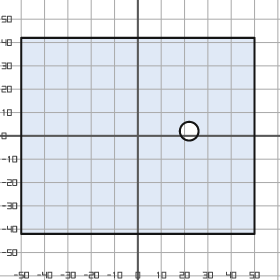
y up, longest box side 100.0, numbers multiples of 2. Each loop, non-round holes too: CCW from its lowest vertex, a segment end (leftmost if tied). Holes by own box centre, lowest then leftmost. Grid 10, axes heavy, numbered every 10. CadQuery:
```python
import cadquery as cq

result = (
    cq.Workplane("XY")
    .moveTo(-50.0, -42.0)
    .lineTo(50.0, -42.0)
    .lineTo(50.0, 42.0)
    .lineTo(-50.0, 42.0)
    .close()
    .moveTo(22.0, 2.0)
    .circle(4.0)
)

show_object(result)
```